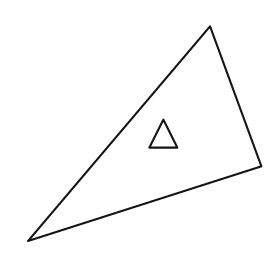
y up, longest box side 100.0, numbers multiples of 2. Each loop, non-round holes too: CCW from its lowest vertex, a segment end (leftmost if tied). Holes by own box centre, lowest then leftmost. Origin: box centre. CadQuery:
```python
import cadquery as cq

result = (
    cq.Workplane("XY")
    .moveTo(-50.0, -46.0)
    .lineTo(50.0, -14.0)
    .lineTo(28.0, 46.0)
    .close()
    .moveTo(2.0, -6.0)
    .lineTo(14.0, -6.0)
    .lineTo(8.0, 6.0)
    .close()
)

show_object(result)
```